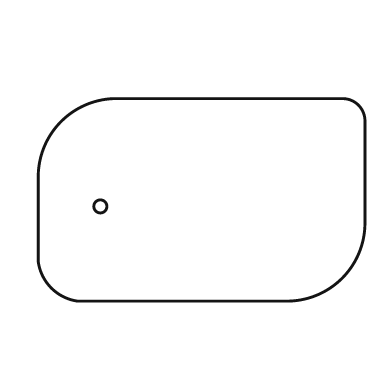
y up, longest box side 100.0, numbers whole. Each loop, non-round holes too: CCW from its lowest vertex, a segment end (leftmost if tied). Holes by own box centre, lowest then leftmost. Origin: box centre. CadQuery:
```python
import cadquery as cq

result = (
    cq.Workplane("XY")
    .moveTo(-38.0, -31.0)
    .lineTo(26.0, -31.0)
    .threePointArc((43.0, -24.0), (50.0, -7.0))
    .lineTo(50.0, 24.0)
    .threePointArc((48.0, 29.0), (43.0, 31.0))
    .lineTo(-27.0, 31.0)
    .threePointArc((-43.0, 24.0), (-50.0, 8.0))
    .lineTo(-50.0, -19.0)
    .threePointArc((-46.0, -27.0), (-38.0, -31.0))
    .close()
    .moveTo(-31.0, -2.0)
    .circle(2.0)
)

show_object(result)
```